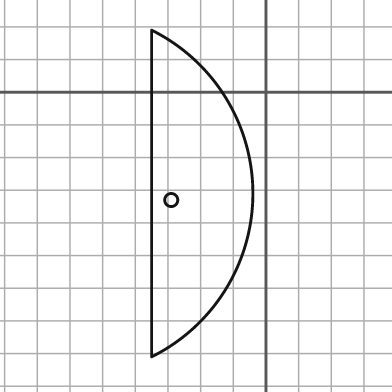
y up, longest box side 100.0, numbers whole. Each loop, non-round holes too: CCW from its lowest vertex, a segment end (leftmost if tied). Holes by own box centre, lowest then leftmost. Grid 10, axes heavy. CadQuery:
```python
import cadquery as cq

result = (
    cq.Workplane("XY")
    .moveTo(-35.0, -81.0)
    .threePointArc((-4.0, -31.0), (-35.0, 19.0))
    .close()
    .moveTo(-29.0, -33.0)
    .circle(2.0)
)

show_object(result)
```